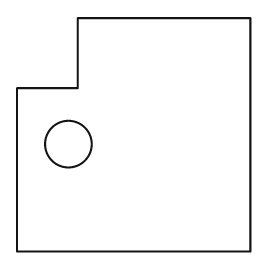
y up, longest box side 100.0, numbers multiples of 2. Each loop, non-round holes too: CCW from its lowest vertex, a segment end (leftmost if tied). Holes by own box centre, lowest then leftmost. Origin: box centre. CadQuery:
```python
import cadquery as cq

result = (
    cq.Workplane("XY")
    .moveTo(-50.0, -50.0)
    .lineTo(50.0, -50.0)
    .lineTo(50.0, 50.0)
    .lineTo(-24.0, 50.0)
    .lineTo(-24.0, 20.0)
    .lineTo(-50.0, 20.0)
    .close()
    .moveTo(-28.0, -4.0)
    .circle(10.0)
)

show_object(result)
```